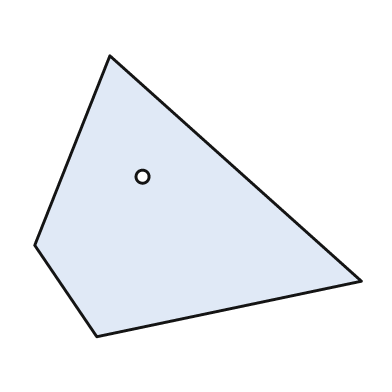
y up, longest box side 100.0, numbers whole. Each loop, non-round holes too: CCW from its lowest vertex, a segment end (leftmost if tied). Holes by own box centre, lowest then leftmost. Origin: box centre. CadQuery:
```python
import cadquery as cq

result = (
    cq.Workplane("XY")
    .moveTo(-31.0, -43.0)
    .lineTo(50.0, -26.0)
    .lineTo(-27.0, 43.0)
    .lineTo(-50.0, -15.0)
    .close()
    .moveTo(-17.0, 6.0)
    .circle(2.0)
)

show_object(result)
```